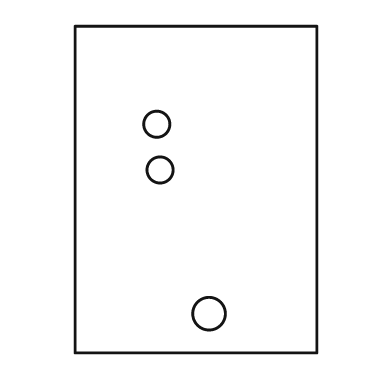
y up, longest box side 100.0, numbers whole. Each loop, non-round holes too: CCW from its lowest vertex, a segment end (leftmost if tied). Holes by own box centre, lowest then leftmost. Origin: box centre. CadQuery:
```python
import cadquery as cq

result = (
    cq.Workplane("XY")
    .moveTo(-37.0, -50.0)
    .lineTo(37.0, -50.0)
    .lineTo(37.0, 50.0)
    .lineTo(-37.0, 50.0)
    .close()
    .moveTo(4.0, -38.0)
    .circle(5.0)
    .moveTo(-11.0, 6.0)
    .circle(4.0)
    .moveTo(-12.0, 20.0)
    .circle(4.0)
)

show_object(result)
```